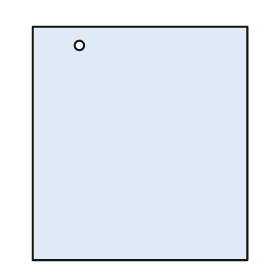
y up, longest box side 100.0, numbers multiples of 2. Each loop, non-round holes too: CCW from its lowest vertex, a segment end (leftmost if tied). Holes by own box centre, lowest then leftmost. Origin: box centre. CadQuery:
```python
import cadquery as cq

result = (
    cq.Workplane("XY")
    .moveTo(-46.0, -50.0)
    .lineTo(46.0, -50.0)
    .lineTo(46.0, 50.0)
    .lineTo(-46.0, 50.0)
    .close()
    .moveTo(-26.0, 42.0)
    .circle(2.0)
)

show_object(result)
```